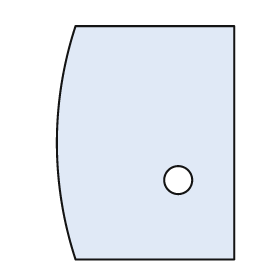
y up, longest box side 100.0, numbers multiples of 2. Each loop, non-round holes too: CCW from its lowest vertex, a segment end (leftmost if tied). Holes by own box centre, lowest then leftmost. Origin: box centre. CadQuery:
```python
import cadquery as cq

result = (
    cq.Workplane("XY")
    .moveTo(-30.0, -50.0)
    .lineTo(38.0, -50.0)
    .lineTo(38.0, 50.0)
    .lineTo(-30.0, 50.0)
    .threePointArc((-38.0, 0.0), (-30.0, -50.0))
    .close()
    .moveTo(14.0, -16.0)
    .circle(6.0)
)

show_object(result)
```